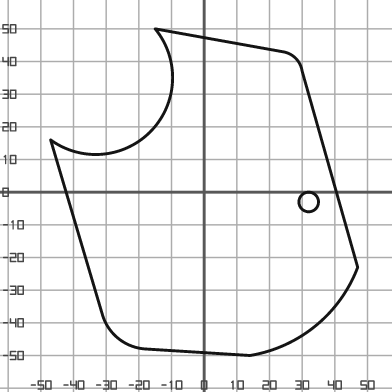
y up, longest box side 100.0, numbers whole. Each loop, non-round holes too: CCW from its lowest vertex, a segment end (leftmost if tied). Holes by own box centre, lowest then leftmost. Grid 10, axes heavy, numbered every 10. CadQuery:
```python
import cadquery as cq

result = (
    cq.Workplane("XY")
    .moveTo(14.0, -50.0)
    .threePointArc((34.0, -41.0), (47.0, -23.0))
    .lineTo(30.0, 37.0)
    .threePointArc((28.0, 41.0), (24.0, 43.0))
    .lineTo(-15.0, 50.0)
    .threePointArc((-16.0, 19.0), (-47.0, 16.0))
    .lineTo(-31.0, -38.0)
    .threePointArc((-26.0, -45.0), (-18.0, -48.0))
    .close()
    .moveTo(32.0, -3.0)
    .circle(3.0)
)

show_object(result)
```